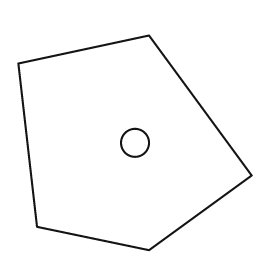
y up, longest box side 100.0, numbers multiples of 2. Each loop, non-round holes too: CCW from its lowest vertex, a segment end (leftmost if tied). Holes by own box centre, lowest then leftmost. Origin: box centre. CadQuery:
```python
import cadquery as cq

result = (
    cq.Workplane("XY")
    .moveTo(6.0, -46.0)
    .lineTo(50.0, -14.0)
    .lineTo(6.0, 46.0)
    .lineTo(-50.0, 34.0)
    .lineTo(-42.0, -36.0)
    .close()
    .moveTo(0.0, 0.0)
    .circle(6.0)
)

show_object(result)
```